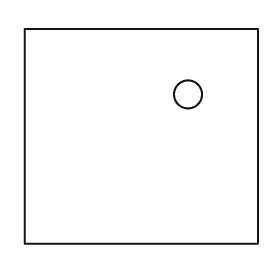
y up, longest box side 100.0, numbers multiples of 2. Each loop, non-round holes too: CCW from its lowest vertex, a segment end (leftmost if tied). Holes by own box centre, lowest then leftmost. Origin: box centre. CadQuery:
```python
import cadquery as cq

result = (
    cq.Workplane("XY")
    .moveTo(-50.0, -46.0)
    .lineTo(50.0, -46.0)
    .lineTo(50.0, 46.0)
    .lineTo(-50.0, 46.0)
    .close()
    .moveTo(20.0, 18.0)
    .circle(6.0)
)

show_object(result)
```